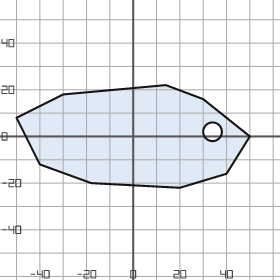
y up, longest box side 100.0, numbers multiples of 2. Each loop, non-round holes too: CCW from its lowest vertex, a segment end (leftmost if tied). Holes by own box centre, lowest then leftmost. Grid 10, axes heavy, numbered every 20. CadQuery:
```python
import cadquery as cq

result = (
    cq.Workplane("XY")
    .moveTo(20.0, -22.0)
    .lineTo(40.0, -16.0)
    .lineTo(50.0, 0.0)
    .lineTo(30.0, 16.0)
    .lineTo(14.0, 22.0)
    .lineTo(-30.0, 18.0)
    .lineTo(-50.0, 8.0)
    .lineTo(-40.0, -12.0)
    .lineTo(-18.0, -20.0)
    .close()
    .moveTo(34.0, 2.0)
    .circle(4.0)
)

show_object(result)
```